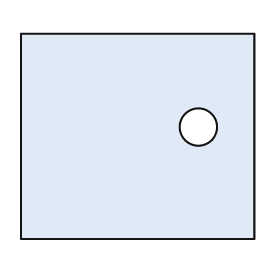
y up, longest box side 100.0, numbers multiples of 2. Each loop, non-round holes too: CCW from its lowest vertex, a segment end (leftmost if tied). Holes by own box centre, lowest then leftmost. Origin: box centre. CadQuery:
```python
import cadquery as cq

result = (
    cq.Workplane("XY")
    .moveTo(-50.0, -44.0)
    .lineTo(50.0, -44.0)
    .lineTo(50.0, 44.0)
    .lineTo(-50.0, 44.0)
    .close()
    .moveTo(26.0, 4.0)
    .circle(8.0)
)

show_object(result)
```